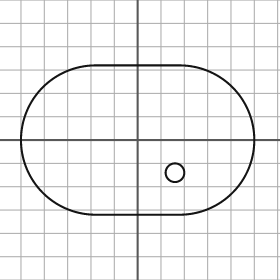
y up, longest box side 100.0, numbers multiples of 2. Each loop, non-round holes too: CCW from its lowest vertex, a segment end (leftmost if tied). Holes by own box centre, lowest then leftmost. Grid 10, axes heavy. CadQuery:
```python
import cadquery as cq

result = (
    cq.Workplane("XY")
    .moveTo(-18.0, -32.0)
    .lineTo(18.0, -32.0)
    .threePointArc((50.0, 0.0), (18.0, 32.0))
    .lineTo(-18.0, 32.0)
    .threePointArc((-50.0, 0.0), (-18.0, -32.0))
    .close()
    .moveTo(16.0, -14.0)
    .circle(4.0)
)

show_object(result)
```